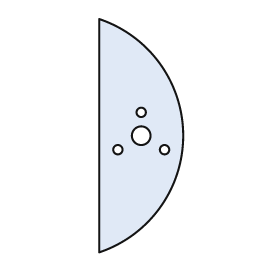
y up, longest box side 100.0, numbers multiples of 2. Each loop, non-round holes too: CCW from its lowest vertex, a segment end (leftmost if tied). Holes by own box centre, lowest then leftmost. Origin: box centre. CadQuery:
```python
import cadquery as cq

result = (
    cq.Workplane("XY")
    .moveTo(-18.0, -50.0)
    .threePointArc((18.0, 0.0), (-18.0, 50.0))
    .close()
    .moveTo(-10.0, -6.0)
    .circle(2.0)
    .moveTo(10.0, -6.0)
    .circle(2.0)
    .moveTo(0.0, 0.0)
    .circle(4.0)
    .moveTo(0.0, 10.0)
    .circle(2.0)
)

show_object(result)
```